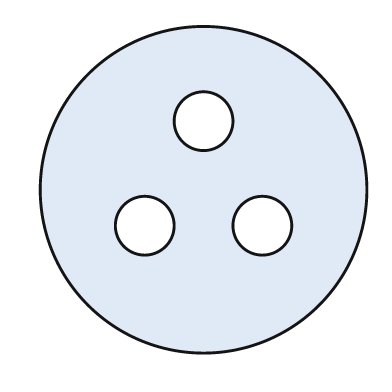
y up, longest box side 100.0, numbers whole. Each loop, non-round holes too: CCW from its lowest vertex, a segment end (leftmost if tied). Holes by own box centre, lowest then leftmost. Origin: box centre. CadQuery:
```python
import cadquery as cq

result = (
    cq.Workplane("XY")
    .moveTo(0.0, 0.0)
    .circle(50.0)
    .moveTo(-18.0, -11.0)
    .circle(9.0)
    .moveTo(18.0, -11.0)
    .circle(9.0)
    .moveTo(0.0, 21.0)
    .circle(9.0)
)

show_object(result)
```